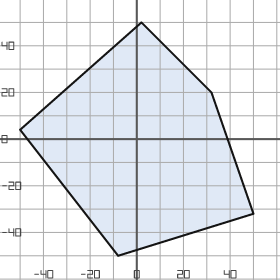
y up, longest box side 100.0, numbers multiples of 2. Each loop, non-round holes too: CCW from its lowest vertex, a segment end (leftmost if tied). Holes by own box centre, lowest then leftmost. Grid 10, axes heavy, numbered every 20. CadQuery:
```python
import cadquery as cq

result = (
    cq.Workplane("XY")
    .moveTo(-8.0, -50.0)
    .lineTo(50.0, -32.0)
    .lineTo(32.0, 20.0)
    .lineTo(2.0, 50.0)
    .lineTo(-50.0, 4.0)
    .close()
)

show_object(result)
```